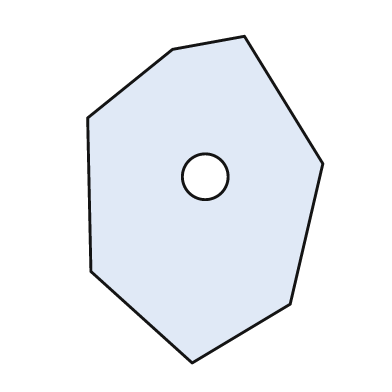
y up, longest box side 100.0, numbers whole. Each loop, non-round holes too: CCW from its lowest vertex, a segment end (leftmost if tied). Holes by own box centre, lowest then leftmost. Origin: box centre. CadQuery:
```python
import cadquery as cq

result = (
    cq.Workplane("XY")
    .moveTo(-4.0, -50.0)
    .lineTo(26.0, -32.0)
    .lineTo(36.0, 11.0)
    .lineTo(12.0, 50.0)
    .lineTo(-10.0, 46.0)
    .lineTo(-36.0, 25.0)
    .lineTo(-35.0, -22.0)
    .close()
    .moveTo(0.0, 7.0)
    .circle(7.0)
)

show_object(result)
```